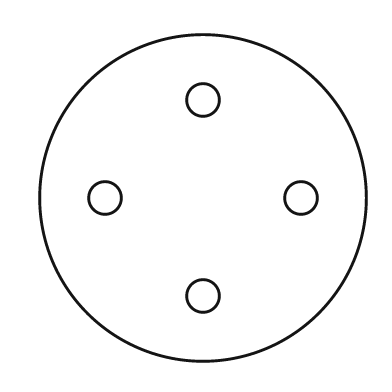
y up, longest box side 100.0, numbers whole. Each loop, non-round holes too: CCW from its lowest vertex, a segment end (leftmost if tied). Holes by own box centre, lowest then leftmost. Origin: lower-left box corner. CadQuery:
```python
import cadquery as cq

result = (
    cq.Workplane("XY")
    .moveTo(50.0, 50.0)
    .circle(50.0)
    .moveTo(50.0, 20.0)
    .circle(5.0)
    .moveTo(20.0, 50.0)
    .circle(5.0)
    .moveTo(80.0, 50.0)
    .circle(5.0)
    .moveTo(50.0, 80.0)
    .circle(5.0)
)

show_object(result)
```